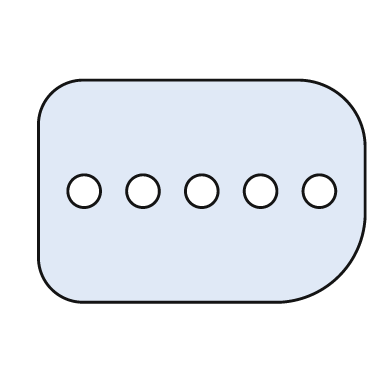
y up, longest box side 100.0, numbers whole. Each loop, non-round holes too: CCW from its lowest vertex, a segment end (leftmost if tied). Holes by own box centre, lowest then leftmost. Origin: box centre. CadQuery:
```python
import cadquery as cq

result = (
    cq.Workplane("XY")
    .moveTo(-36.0, -34.0)
    .lineTo(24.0, -34.0)
    .threePointArc((42.0, -26.0), (50.0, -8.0))
    .lineTo(50.0, 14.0)
    .threePointArc((44.0, 28.0), (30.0, 34.0))
    .lineTo(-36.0, 34.0)
    .threePointArc((-46.0, 30.0), (-50.0, 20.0))
    .lineTo(-50.0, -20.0)
    .threePointArc((-46.0, -30.0), (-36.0, -34.0))
    .close()
    .moveTo(-36.0, 0.0)
    .circle(5.0)
    .moveTo(-18.0, 0.0)
    .circle(5.0)
    .moveTo(0.0, 0.0)
    .circle(5.0)
    .moveTo(18.0, 0.0)
    .circle(5.0)
    .moveTo(36.0, 0.0)
    .circle(5.0)
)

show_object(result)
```